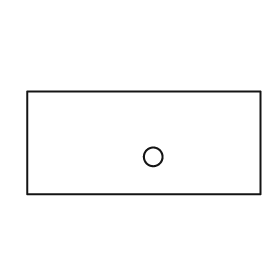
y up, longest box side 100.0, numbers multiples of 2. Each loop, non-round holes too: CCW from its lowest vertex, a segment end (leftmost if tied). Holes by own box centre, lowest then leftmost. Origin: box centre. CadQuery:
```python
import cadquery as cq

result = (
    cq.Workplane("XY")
    .moveTo(-50.0, -22.0)
    .lineTo(50.0, -22.0)
    .lineTo(50.0, 22.0)
    .lineTo(-50.0, 22.0)
    .close()
    .moveTo(4.0, -6.0)
    .circle(4.0)
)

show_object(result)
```